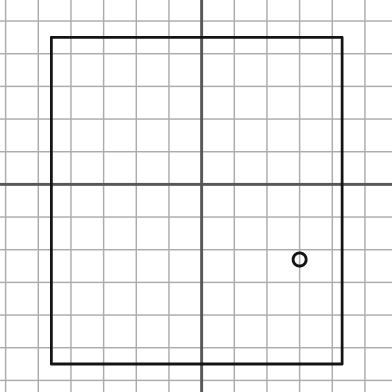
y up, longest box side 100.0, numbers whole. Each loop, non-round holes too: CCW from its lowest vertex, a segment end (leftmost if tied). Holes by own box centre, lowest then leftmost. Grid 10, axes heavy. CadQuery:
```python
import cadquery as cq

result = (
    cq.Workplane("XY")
    .moveTo(-46.0, -55.0)
    .lineTo(43.0, -55.0)
    .lineTo(43.0, 45.0)
    .lineTo(-46.0, 45.0)
    .close()
    .moveTo(30.0, -23.0)
    .circle(2.0)
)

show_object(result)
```